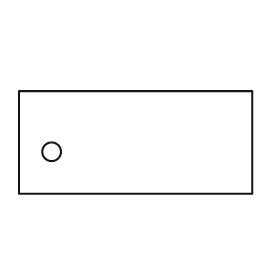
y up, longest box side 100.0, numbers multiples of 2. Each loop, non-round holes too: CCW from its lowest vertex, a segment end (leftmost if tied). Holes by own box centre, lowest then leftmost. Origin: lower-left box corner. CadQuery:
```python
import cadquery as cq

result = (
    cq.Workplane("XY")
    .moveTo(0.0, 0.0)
    .lineTo(100.0, 0.0)
    .lineTo(100.0, 44.0)
    .lineTo(0.0, 44.0)
    .close()
    .moveTo(14.0, 18.0)
    .circle(4.0)
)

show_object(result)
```